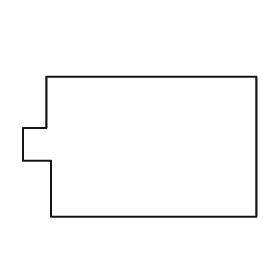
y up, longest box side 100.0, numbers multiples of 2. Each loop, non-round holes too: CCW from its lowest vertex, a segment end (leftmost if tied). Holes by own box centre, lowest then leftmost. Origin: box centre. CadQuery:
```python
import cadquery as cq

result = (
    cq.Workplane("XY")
    .moveTo(-38.0, -30.0)
    .lineTo(50.0, -30.0)
    .lineTo(50.0, 30.0)
    .lineTo(-40.0, 30.0)
    .lineTo(-40.0, 8.0)
    .lineTo(-50.0, 8.0)
    .lineTo(-50.0, -6.0)
    .lineTo(-38.0, -6.0)
    .close()
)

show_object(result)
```